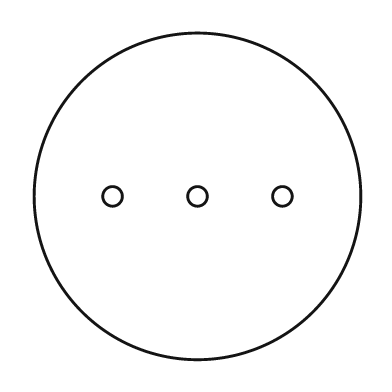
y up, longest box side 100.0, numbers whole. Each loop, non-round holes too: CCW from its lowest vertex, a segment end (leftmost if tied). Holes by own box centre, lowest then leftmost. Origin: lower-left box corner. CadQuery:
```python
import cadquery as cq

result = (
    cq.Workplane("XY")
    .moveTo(50.0, 50.0)
    .circle(50.0)
    .moveTo(24.0, 50.0)
    .circle(3.0)
    .moveTo(50.0, 50.0)
    .circle(3.0)
    .moveTo(76.0, 50.0)
    .circle(3.0)
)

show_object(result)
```